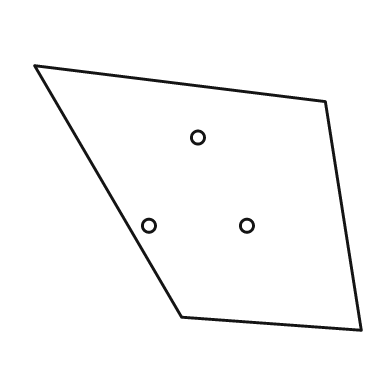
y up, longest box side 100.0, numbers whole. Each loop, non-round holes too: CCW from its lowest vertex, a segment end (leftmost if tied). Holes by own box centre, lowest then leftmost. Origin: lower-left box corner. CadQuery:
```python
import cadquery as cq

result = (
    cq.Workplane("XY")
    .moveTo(100.0, 0.0)
    .lineTo(89.0, 70.0)
    .lineTo(0.0, 81.0)
    .lineTo(45.0, 4.0)
    .close()
    .moveTo(35.0, 32.0)
    .circle(2.0)
    .moveTo(65.0, 32.0)
    .circle(2.0)
    .moveTo(50.0, 59.0)
    .circle(2.0)
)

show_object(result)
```